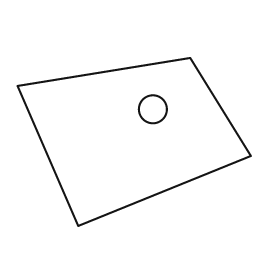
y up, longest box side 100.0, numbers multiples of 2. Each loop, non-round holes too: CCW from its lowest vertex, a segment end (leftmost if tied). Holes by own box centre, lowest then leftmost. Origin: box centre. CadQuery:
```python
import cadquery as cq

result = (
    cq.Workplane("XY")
    .moveTo(-24.0, -36.0)
    .lineTo(50.0, -6.0)
    .lineTo(24.0, 36.0)
    .lineTo(-50.0, 24.0)
    .close()
    .moveTo(8.0, 14.0)
    .circle(6.0)
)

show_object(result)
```